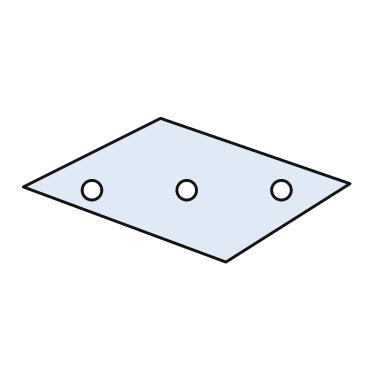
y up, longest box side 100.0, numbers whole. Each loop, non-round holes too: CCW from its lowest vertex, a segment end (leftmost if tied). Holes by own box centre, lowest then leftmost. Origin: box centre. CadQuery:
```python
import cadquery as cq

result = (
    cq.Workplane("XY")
    .moveTo(12.0, -22.0)
    .lineTo(50.0, 2.0)
    .lineTo(-8.0, 22.0)
    .lineTo(-50.0, 1.0)
    .close()
    .moveTo(-29.0, 0.0)
    .circle(3.0)
    .moveTo(0.0, 0.0)
    .circle(3.0)
    .moveTo(29.0, 0.0)
    .circle(3.0)
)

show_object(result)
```